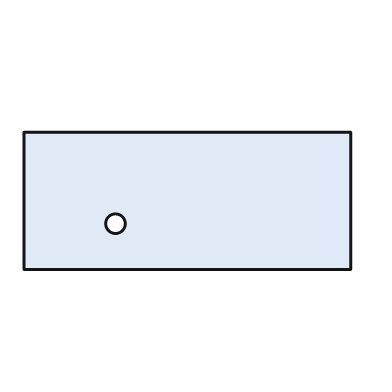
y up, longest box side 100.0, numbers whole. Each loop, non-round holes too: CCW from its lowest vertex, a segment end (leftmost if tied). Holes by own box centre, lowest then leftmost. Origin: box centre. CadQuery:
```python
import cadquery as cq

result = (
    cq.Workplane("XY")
    .moveTo(-50.0, -21.0)
    .lineTo(50.0, -21.0)
    .lineTo(50.0, 21.0)
    .lineTo(-50.0, 21.0)
    .close()
    .moveTo(-22.0, -7.0)
    .circle(3.0)
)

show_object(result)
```